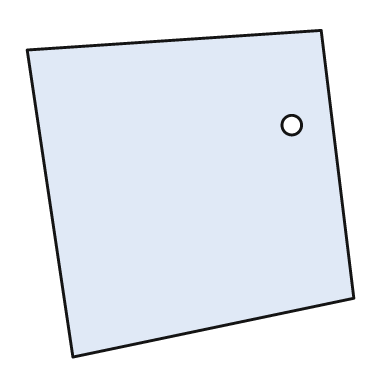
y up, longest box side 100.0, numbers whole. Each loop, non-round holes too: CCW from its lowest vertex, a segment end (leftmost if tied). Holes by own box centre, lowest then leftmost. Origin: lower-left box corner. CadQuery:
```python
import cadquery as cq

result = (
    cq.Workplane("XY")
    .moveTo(14.0, 0.0)
    .lineTo(100.0, 18.0)
    .lineTo(90.0, 100.0)
    .lineTo(0.0, 94.0)
    .close()
    .moveTo(81.0, 71.0)
    .circle(3.0)
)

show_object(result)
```